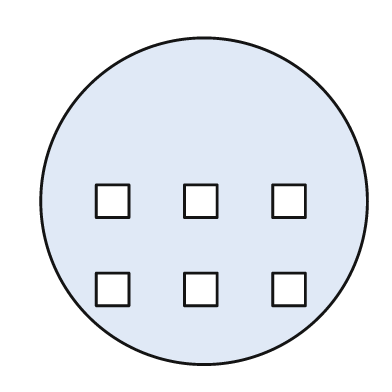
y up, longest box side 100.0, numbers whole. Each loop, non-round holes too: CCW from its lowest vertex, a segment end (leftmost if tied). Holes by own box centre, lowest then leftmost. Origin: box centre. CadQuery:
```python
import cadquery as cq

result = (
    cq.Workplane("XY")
    .moveTo(0.0, 0.0)
    .circle(50.0)
    .moveTo(-33.0, -32.0)
    .lineTo(-23.0, -32.0)
    .lineTo(-23.0, -22.0)
    .lineTo(-33.0, -22.0)
    .close()
    .moveTo(-6.0, -32.0)
    .lineTo(4.0, -32.0)
    .lineTo(4.0, -22.0)
    .lineTo(-6.0, -22.0)
    .close()
    .moveTo(21.0, -32.0)
    .lineTo(31.0, -32.0)
    .lineTo(31.0, -22.0)
    .lineTo(21.0, -22.0)
    .close()
    .moveTo(-33.0, -5.0)
    .lineTo(-23.0, -5.0)
    .lineTo(-23.0, 5.0)
    .lineTo(-33.0, 5.0)
    .close()
    .moveTo(-6.0, -5.0)
    .lineTo(4.0, -5.0)
    .lineTo(4.0, 5.0)
    .lineTo(-6.0, 5.0)
    .close()
    .moveTo(21.0, -5.0)
    .lineTo(31.0, -5.0)
    .lineTo(31.0, 5.0)
    .lineTo(21.0, 5.0)
    .close()
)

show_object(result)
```